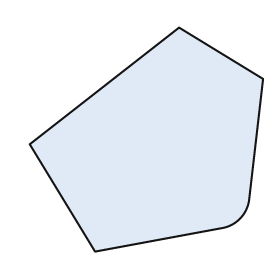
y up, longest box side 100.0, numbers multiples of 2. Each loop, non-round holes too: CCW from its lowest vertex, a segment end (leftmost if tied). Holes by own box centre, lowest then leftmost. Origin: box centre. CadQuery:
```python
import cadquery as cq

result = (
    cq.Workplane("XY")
    .moveTo(-22.0, -48.0)
    .lineTo(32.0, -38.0)
    .threePointArc((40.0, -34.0), (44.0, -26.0))
    .lineTo(50.0, 26.0)
    .lineTo(14.0, 48.0)
    .lineTo(-50.0, -2.0)
    .close()
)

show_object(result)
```